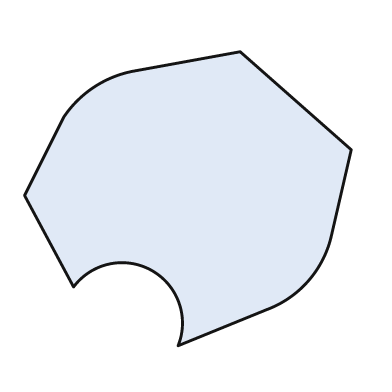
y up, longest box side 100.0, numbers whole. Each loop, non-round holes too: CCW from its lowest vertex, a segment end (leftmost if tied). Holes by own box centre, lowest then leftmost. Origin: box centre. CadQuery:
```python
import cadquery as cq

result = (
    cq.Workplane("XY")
    .moveTo(-3.0, -45.0)
    .lineTo(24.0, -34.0)
    .threePointArc((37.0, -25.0), (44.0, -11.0))
    .lineTo(50.0, 15.0)
    .lineTo(16.0, 45.0)
    .lineTo(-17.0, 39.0)
    .threePointArc((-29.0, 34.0), (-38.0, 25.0))
    .lineTo(-50.0, 1.0)
    .lineTo(-35.0, -27.0)
    .threePointArc((-11.0, -22.0), (-3.0, -45.0))
    .close()
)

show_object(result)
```